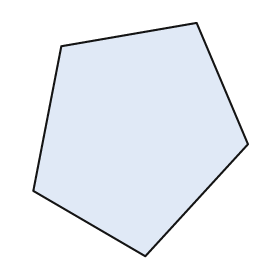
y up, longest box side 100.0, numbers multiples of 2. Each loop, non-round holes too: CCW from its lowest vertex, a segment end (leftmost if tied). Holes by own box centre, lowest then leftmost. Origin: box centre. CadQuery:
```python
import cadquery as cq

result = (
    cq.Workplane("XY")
    .moveTo(2.0, -50.0)
    .lineTo(46.0, -2.0)
    .lineTo(24.0, 50.0)
    .lineTo(-34.0, 40.0)
    .lineTo(-46.0, -22.0)
    .close()
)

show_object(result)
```